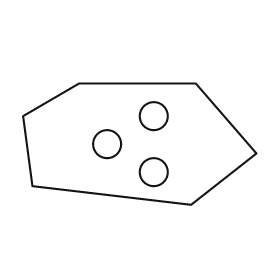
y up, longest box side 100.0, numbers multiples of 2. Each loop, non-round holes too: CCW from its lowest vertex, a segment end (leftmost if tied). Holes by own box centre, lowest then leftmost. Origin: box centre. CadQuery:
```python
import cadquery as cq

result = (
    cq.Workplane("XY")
    .moveTo(22.0, -26.0)
    .lineTo(50.0, -4.0)
    .lineTo(24.0, 26.0)
    .lineTo(-26.0, 26.0)
    .lineTo(-50.0, 12.0)
    .lineTo(-46.0, -18.0)
    .close()
    .moveTo(6.0, -12.0)
    .circle(6.0)
    .moveTo(-14.0, 0.0)
    .circle(6.0)
    .moveTo(6.0, 12.0)
    .circle(6.0)
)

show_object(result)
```